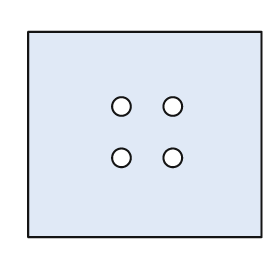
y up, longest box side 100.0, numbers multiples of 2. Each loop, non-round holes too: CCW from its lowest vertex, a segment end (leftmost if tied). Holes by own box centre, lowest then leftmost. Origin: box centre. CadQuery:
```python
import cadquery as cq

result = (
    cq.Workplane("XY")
    .moveTo(-50.0, -44.0)
    .lineTo(50.0, -44.0)
    .lineTo(50.0, 44.0)
    .lineTo(-50.0, 44.0)
    .close()
    .moveTo(-10.0, -10.0)
    .circle(4.0)
    .moveTo(12.0, -10.0)
    .circle(4.0)
    .moveTo(-10.0, 12.0)
    .circle(4.0)
    .moveTo(12.0, 12.0)
    .circle(4.0)
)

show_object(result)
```